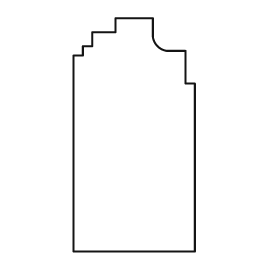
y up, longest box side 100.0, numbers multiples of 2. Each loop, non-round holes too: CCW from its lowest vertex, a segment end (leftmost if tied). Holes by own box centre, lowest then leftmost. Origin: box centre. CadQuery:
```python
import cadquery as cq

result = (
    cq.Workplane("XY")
    .moveTo(-26.0, -50.0)
    .lineTo(26.0, -50.0)
    .lineTo(26.0, 22.0)
    .lineTo(22.0, 22.0)
    .lineTo(22.0, 36.0)
    .lineTo(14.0, 36.0)
    .threePointArc((10.0, 38.0), (8.0, 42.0))
    .lineTo(8.0, 50.0)
    .lineTo(-8.0, 50.0)
    .lineTo(-8.0, 44.0)
    .lineTo(-18.0, 44.0)
    .lineTo(-18.0, 38.0)
    .lineTo(-22.0, 38.0)
    .lineTo(-22.0, 34.0)
    .lineTo(-26.0, 34.0)
    .close()
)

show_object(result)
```